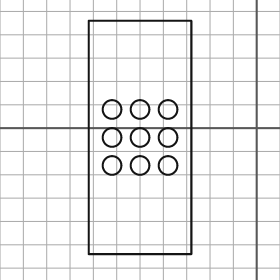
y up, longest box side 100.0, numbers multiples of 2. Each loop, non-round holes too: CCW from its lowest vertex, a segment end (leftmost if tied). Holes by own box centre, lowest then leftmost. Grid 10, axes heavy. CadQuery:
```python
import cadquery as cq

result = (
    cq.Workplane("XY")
    .moveTo(-72.0, -54.0)
    .lineTo(-28.0, -54.0)
    .lineTo(-28.0, 46.0)
    .lineTo(-72.0, 46.0)
    .close()
    .moveTo(-62.0, -16.0)
    .circle(4.0)
    .moveTo(-50.0, -16.0)
    .circle(4.0)
    .moveTo(-38.0, -16.0)
    .circle(4.0)
    .moveTo(-62.0, -4.0)
    .circle(4.0)
    .moveTo(-50.0, -4.0)
    .circle(4.0)
    .moveTo(-38.0, -4.0)
    .circle(4.0)
    .moveTo(-62.0, 8.0)
    .circle(4.0)
    .moveTo(-50.0, 8.0)
    .circle(4.0)
    .moveTo(-38.0, 8.0)
    .circle(4.0)
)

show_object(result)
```